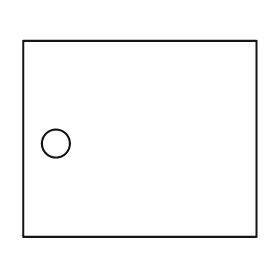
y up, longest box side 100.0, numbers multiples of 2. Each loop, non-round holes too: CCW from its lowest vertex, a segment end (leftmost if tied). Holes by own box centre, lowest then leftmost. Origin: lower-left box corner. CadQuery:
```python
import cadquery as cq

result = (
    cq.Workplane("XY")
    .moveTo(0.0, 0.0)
    .lineTo(100.0, 0.0)
    .lineTo(100.0, 84.0)
    .lineTo(0.0, 84.0)
    .close()
    .moveTo(14.0, 40.0)
    .circle(6.0)
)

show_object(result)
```